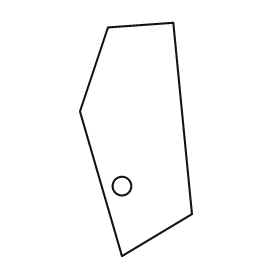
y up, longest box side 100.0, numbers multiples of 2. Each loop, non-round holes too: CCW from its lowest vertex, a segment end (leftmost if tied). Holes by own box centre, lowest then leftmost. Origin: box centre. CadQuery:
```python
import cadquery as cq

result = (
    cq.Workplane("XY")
    .moveTo(-6.0, -50.0)
    .lineTo(24.0, -32.0)
    .lineTo(16.0, 50.0)
    .lineTo(-12.0, 48.0)
    .lineTo(-24.0, 12.0)
    .close()
    .moveTo(-6.0, -20.0)
    .circle(4.0)
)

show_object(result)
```